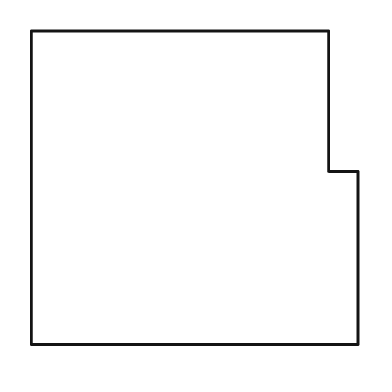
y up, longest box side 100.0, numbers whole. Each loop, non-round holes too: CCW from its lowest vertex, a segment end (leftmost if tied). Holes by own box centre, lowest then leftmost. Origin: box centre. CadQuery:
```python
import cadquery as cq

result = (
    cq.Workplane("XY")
    .moveTo(-50.0, -48.0)
    .lineTo(50.0, -48.0)
    .lineTo(50.0, 5.0)
    .lineTo(41.0, 5.0)
    .lineTo(41.0, 48.0)
    .lineTo(-50.0, 48.0)
    .close()
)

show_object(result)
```